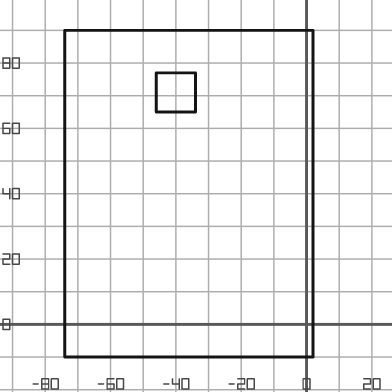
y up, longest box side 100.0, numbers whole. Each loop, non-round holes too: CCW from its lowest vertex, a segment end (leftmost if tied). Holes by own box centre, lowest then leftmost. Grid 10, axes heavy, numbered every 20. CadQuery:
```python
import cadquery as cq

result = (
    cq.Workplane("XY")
    .moveTo(-74.0, -10.0)
    .lineTo(2.0, -10.0)
    .lineTo(2.0, 90.0)
    .lineTo(-74.0, 90.0)
    .close()
    .moveTo(-46.0, 65.0)
    .lineTo(-34.0, 65.0)
    .lineTo(-34.0, 77.0)
    .lineTo(-46.0, 77.0)
    .close()
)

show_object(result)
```